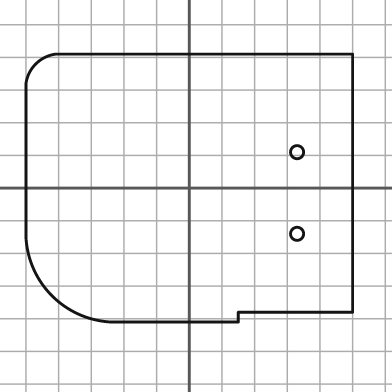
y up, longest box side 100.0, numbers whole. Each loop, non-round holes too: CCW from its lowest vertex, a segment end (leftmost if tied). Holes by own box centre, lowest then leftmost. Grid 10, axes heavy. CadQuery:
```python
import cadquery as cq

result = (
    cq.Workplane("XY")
    .moveTo(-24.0, -41.0)
    .lineTo(15.0, -41.0)
    .lineTo(15.0, -38.0)
    .lineTo(50.0, -38.0)
    .lineTo(50.0, 41.0)
    .lineTo(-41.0, 41.0)
    .threePointArc((-47.0, 38.0), (-50.0, 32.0))
    .lineTo(-50.0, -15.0)
    .threePointArc((-42.0, -33.0), (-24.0, -41.0))
    .close()
    .moveTo(33.0, -14.0)
    .circle(2.0)
    .moveTo(33.0, 11.0)
    .circle(2.0)
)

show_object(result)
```